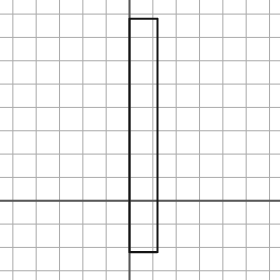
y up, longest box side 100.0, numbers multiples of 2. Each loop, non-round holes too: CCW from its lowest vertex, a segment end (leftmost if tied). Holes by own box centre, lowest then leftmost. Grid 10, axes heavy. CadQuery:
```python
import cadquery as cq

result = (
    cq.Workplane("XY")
    .moveTo(0.0, -22.0)
    .lineTo(12.0, -22.0)
    .lineTo(12.0, 78.0)
    .lineTo(0.0, 78.0)
    .close()
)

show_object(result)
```